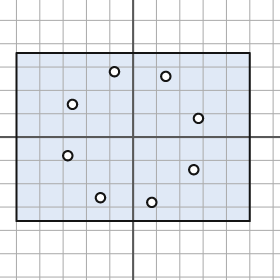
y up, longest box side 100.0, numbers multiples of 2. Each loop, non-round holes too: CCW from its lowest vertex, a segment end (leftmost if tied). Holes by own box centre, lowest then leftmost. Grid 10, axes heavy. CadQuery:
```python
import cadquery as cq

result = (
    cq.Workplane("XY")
    .moveTo(-50.0, -36.0)
    .lineTo(50.0, -36.0)
    .lineTo(50.0, 36.0)
    .lineTo(-50.0, 36.0)
    .close()
    .moveTo(8.0, -28.0)
    .circle(2.0)
    .moveTo(-14.0, -26.0)
    .circle(2.0)
    .moveTo(26.0, -14.0)
    .circle(2.0)
    .moveTo(-28.0, -8.0)
    .circle(2.0)
    .moveTo(28.0, 8.0)
    .circle(2.0)
    .moveTo(-26.0, 14.0)
    .circle(2.0)
    .moveTo(14.0, 26.0)
    .circle(2.0)
    .moveTo(-8.0, 28.0)
    .circle(2.0)
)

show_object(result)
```